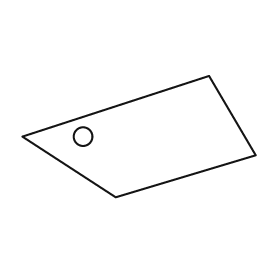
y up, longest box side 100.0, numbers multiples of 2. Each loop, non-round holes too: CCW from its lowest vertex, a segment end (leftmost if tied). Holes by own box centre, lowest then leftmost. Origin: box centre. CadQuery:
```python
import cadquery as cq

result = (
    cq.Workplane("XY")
    .moveTo(-10.0, -26.0)
    .lineTo(50.0, -8.0)
    .lineTo(30.0, 26.0)
    .lineTo(-50.0, 0.0)
    .close()
    .moveTo(-24.0, 0.0)
    .circle(4.0)
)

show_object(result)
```